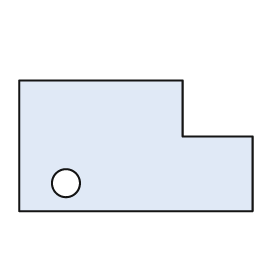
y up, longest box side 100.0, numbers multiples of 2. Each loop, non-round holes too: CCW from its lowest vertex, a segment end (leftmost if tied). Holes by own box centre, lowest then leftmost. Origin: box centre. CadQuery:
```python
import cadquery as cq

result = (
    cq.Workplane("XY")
    .moveTo(-50.0, -28.0)
    .lineTo(50.0, -28.0)
    .lineTo(50.0, 4.0)
    .lineTo(20.0, 4.0)
    .lineTo(20.0, 28.0)
    .lineTo(-50.0, 28.0)
    .close()
    .moveTo(-30.0, -16.0)
    .circle(6.0)
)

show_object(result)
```